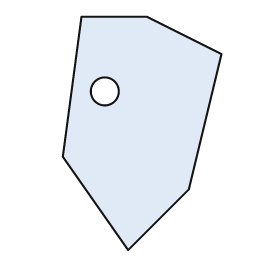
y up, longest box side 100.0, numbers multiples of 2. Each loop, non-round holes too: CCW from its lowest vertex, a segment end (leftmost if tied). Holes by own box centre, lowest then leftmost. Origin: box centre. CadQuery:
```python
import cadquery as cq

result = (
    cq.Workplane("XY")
    .moveTo(-6.0, -50.0)
    .lineTo(20.0, -24.0)
    .lineTo(34.0, 34.0)
    .lineTo(2.0, 50.0)
    .lineTo(-26.0, 50.0)
    .lineTo(-34.0, -10.0)
    .close()
    .moveTo(-16.0, 18.0)
    .circle(6.0)
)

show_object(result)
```